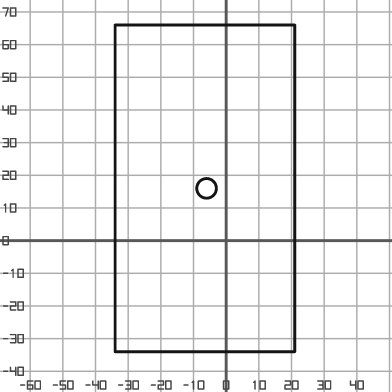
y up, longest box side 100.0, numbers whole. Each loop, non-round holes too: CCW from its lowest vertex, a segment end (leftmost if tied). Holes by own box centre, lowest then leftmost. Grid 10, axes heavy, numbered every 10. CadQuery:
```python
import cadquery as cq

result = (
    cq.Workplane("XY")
    .moveTo(-34.0, -34.0)
    .lineTo(21.0, -34.0)
    .lineTo(21.0, 66.0)
    .lineTo(-34.0, 66.0)
    .close()
    .moveTo(-6.0, 16.0)
    .circle(3.0)
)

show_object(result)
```